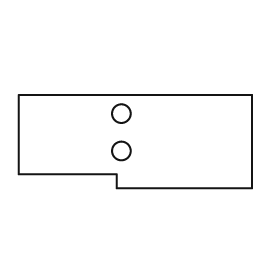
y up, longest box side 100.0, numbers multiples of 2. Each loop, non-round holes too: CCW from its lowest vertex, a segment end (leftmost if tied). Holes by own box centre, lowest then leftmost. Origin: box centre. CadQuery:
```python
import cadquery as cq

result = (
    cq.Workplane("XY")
    .moveTo(-8.0, -20.0)
    .lineTo(50.0, -20.0)
    .lineTo(50.0, 20.0)
    .lineTo(-50.0, 20.0)
    .lineTo(-50.0, -14.0)
    .lineTo(-8.0, -14.0)
    .close()
    .moveTo(-6.0, -4.0)
    .circle(4.0)
    .moveTo(-6.0, 12.0)
    .circle(4.0)
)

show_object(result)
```